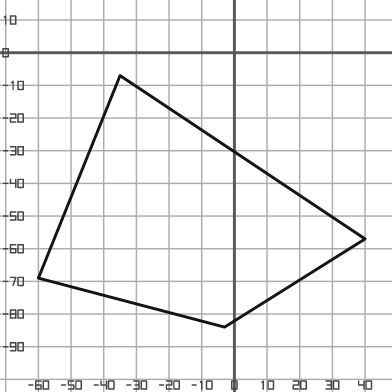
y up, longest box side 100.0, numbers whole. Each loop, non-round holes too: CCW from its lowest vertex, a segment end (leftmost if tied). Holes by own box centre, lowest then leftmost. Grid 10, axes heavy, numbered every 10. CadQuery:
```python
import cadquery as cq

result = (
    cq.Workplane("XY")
    .moveTo(-3.0, -84.0)
    .lineTo(40.0, -57.0)
    .lineTo(-35.0, -7.0)
    .lineTo(-60.0, -69.0)
    .close()
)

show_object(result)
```